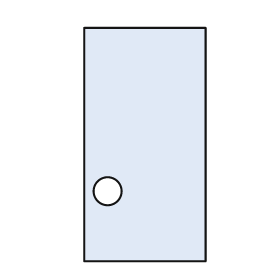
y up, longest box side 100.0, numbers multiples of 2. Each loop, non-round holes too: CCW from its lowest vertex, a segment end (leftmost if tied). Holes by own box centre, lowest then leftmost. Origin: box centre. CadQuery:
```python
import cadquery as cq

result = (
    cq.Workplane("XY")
    .moveTo(-26.0, -50.0)
    .lineTo(26.0, -50.0)
    .lineTo(26.0, 50.0)
    .lineTo(-26.0, 50.0)
    .close()
    .moveTo(-16.0, -20.0)
    .circle(6.0)
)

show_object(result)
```